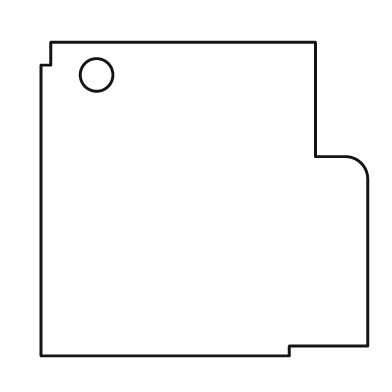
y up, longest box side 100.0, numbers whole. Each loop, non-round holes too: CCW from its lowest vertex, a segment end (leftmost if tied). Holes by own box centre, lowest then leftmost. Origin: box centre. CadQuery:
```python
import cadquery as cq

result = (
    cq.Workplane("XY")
    .moveTo(-50.0, -48.0)
    .lineTo(26.0, -48.0)
    .lineTo(26.0, -45.0)
    .lineTo(50.0, -45.0)
    .lineTo(50.0, 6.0)
    .threePointArc((48.0, 11.0), (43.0, 13.0))
    .lineTo(34.0, 13.0)
    .lineTo(34.0, 48.0)
    .lineTo(-47.0, 48.0)
    .lineTo(-47.0, 41.0)
    .lineTo(-50.0, 41.0)
    .close()
    .moveTo(-33.0, 38.0)
    .circle(5.0)
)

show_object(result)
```